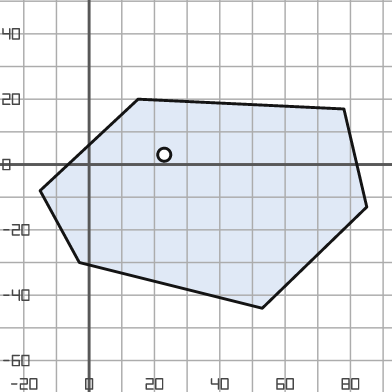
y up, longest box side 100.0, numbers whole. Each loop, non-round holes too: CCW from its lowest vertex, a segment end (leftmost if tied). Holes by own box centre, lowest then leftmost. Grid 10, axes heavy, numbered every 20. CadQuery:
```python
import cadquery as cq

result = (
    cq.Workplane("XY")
    .moveTo(53.0, -44.0)
    .lineTo(85.0, -13.0)
    .lineTo(78.0, 17.0)
    .lineTo(15.0, 20.0)
    .lineTo(-15.0, -8.0)
    .lineTo(-3.0, -30.0)
    .close()
    .moveTo(23.0, 3.0)
    .circle(2.0)
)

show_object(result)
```